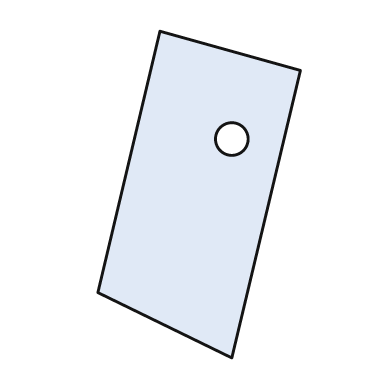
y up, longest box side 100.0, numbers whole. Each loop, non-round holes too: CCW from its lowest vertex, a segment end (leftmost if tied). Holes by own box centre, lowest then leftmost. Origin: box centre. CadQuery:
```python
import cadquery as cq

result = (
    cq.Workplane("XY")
    .moveTo(10.0, -50.0)
    .lineTo(31.0, 38.0)
    .lineTo(-12.0, 50.0)
    .lineTo(-31.0, -30.0)
    .close()
    .moveTo(10.0, 17.0)
    .circle(5.0)
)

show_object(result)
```